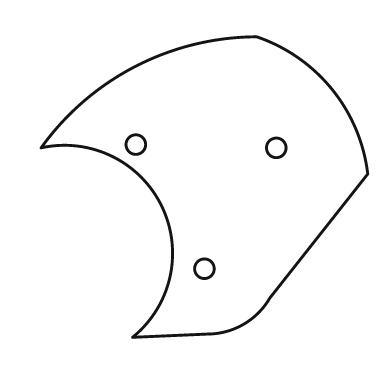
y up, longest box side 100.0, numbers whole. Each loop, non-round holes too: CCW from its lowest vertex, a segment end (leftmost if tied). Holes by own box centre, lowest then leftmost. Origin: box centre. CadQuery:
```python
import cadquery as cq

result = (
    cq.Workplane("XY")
    .moveTo(-22.0, -46.0)
    .lineTo(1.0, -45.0)
    .threePointArc((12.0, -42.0), (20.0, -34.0))
    .lineTo(50.0, 4.0)
    .threePointArc((39.0, 30.0), (16.0, 46.0))
    .threePointArc((-21.0, 37.0), (-50.0, 12.0))
    .threePointArc((-13.0, -6.0), (-22.0, -46.0))
    .close()
    .moveTo(0.0, -25.0)
    .circle(3.0)
    .moveTo(22.0, 12.0)
    .circle(3.0)
    .moveTo(-21.0, 13.0)
    .circle(3.0)
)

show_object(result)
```